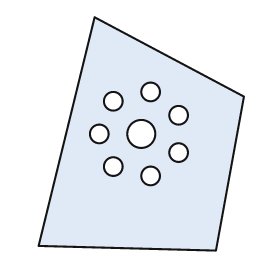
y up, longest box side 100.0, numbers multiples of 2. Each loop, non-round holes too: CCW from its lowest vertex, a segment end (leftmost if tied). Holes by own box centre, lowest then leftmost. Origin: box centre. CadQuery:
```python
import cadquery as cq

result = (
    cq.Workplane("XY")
    .moveTo(32.0, -50.0)
    .lineTo(44.0, 16.0)
    .lineTo(-20.0, 50.0)
    .lineTo(-44.0, -48.0)
    .close()
    .moveTo(4.0, -18.0)
    .circle(4.0)
    .moveTo(-12.0, -14.0)
    .circle(4.0)
    .moveTo(16.0, -8.0)
    .circle(4.0)
    .moveTo(-18.0, 0.0)
    .circle(4.0)
    .moveTo(0.0, 0.0)
    .circle(6.0)
    .moveTo(16.0, 8.0)
    .circle(4.0)
    .moveTo(-12.0, 14.0)
    .circle(4.0)
    .moveTo(4.0, 18.0)
    .circle(4.0)
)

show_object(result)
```